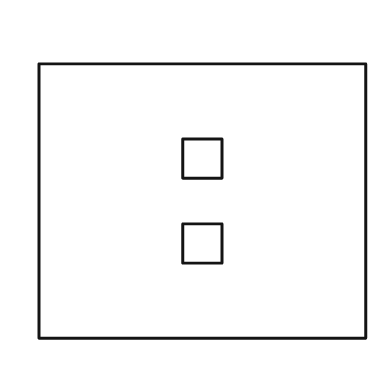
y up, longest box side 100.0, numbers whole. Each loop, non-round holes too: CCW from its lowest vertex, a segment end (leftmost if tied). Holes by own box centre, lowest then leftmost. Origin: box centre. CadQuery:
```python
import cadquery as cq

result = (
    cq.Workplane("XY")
    .moveTo(-50.0, -42.0)
    .lineTo(50.0, -42.0)
    .lineTo(50.0, 42.0)
    .lineTo(-50.0, 42.0)
    .close()
    .moveTo(-6.0, -19.0)
    .lineTo(6.0, -19.0)
    .lineTo(6.0, -7.0)
    .lineTo(-6.0, -7.0)
    .close()
    .moveTo(-6.0, 7.0)
    .lineTo(6.0, 7.0)
    .lineTo(6.0, 19.0)
    .lineTo(-6.0, 19.0)
    .close()
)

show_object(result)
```